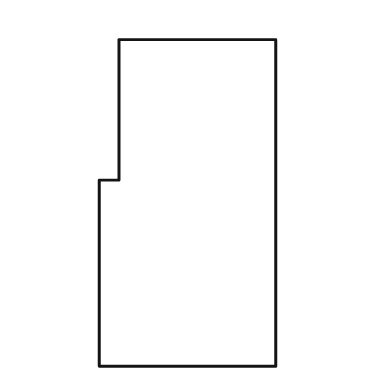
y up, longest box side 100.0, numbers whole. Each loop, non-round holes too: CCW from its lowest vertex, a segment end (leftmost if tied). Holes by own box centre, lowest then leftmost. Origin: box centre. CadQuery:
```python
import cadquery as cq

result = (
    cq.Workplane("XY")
    .moveTo(-27.0, -50.0)
    .lineTo(27.0, -50.0)
    .lineTo(27.0, 50.0)
    .lineTo(-21.0, 50.0)
    .lineTo(-21.0, 7.0)
    .lineTo(-27.0, 7.0)
    .close()
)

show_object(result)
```